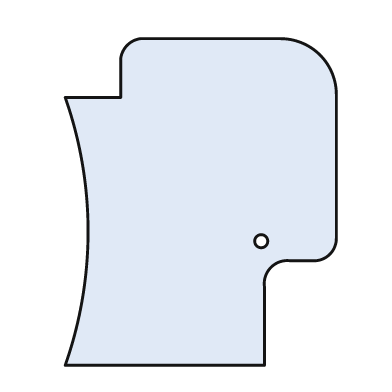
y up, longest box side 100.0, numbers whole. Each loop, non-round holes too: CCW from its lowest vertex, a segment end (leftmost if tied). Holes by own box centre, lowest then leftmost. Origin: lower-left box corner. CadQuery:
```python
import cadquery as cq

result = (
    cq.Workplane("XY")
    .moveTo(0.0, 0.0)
    .lineTo(61.0, 0.0)
    .lineTo(61.0, 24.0)
    .threePointArc((63.0, 30.0), (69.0, 32.0))
    .lineTo(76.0, 32.0)
    .threePointArc((81.0, 34.0), (83.0, 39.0))
    .lineTo(83.0, 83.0)
    .threePointArc((78.0, 95.0), (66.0, 100.0))
    .lineTo(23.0, 100.0)
    .threePointArc((19.0, 98.0), (17.0, 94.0))
    .lineTo(17.0, 82.0)
    .lineTo(0.0, 82.0)
    .threePointArc((7.0, 41.0), (0.0, 0.0))
    .close()
    .moveTo(60.0, 38.0)
    .circle(2.0)
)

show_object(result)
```